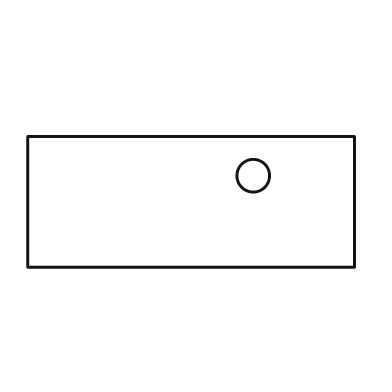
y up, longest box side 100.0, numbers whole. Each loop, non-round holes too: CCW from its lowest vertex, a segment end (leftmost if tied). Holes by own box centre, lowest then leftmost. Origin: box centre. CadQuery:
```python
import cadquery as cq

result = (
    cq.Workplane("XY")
    .moveTo(-50.0, -20.0)
    .lineTo(50.0, -20.0)
    .lineTo(50.0, 20.0)
    .lineTo(-50.0, 20.0)
    .close()
    .moveTo(19.0, 8.0)
    .circle(5.0)
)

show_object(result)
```